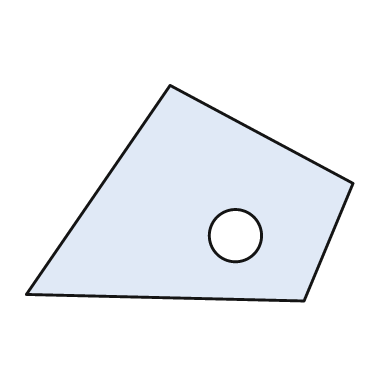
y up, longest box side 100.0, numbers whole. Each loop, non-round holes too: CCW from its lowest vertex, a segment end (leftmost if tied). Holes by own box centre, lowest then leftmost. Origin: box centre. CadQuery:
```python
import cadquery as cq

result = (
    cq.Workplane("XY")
    .moveTo(35.0, -33.0)
    .lineTo(50.0, 3.0)
    .lineTo(-6.0, 33.0)
    .lineTo(-50.0, -31.0)
    .close()
    .moveTo(14.0, -13.0)
    .circle(8.0)
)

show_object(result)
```